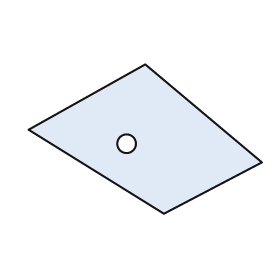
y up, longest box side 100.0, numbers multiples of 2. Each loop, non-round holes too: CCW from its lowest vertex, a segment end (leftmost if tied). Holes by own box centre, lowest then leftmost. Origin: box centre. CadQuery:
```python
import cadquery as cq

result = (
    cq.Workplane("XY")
    .moveTo(8.0, -32.0)
    .lineTo(50.0, -10.0)
    .lineTo(0.0, 32.0)
    .lineTo(-50.0, 4.0)
    .close()
    .moveTo(-8.0, -2.0)
    .circle(4.0)
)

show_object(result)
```